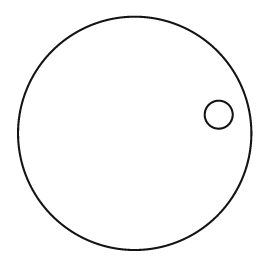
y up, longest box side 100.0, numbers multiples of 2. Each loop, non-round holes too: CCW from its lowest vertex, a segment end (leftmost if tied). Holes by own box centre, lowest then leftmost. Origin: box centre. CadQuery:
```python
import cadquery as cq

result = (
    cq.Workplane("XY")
    .moveTo(0.0, 0.0)
    .circle(50.0)
    .moveTo(36.0, 8.0)
    .circle(6.0)
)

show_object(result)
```